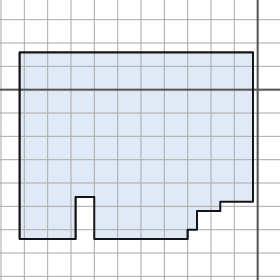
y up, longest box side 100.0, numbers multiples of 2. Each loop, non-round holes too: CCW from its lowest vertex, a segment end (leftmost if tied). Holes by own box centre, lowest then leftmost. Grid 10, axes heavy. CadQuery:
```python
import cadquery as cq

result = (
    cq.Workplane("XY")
    .moveTo(-102.0, -64.0)
    .lineTo(-78.0, -64.0)
    .lineTo(-78.0, -46.0)
    .lineTo(-70.0, -46.0)
    .lineTo(-70.0, -64.0)
    .lineTo(-30.0, -64.0)
    .lineTo(-30.0, -60.0)
    .lineTo(-26.0, -60.0)
    .lineTo(-26.0, -52.0)
    .lineTo(-16.0, -52.0)
    .lineTo(-16.0, -48.0)
    .lineTo(-2.0, -48.0)
    .lineTo(-2.0, 16.0)
    .lineTo(-102.0, 16.0)
    .close()
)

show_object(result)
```